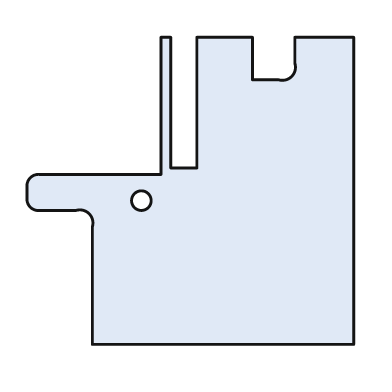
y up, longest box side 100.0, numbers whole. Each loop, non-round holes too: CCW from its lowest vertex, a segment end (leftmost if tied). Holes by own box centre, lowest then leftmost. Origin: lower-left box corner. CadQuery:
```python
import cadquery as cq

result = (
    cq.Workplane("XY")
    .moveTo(20.0, 0.0)
    .lineTo(100.0, 0.0)
    .lineTo(100.0, 94.0)
    .lineTo(82.0, 94.0)
    .lineTo(82.0, 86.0)
    .threePointArc((81.0, 82.0), (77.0, 81.0))
    .lineTo(69.0, 81.0)
    .lineTo(69.0, 94.0)
    .lineTo(52.0, 94.0)
    .lineTo(52.0, 54.0)
    .lineTo(44.0, 54.0)
    .lineTo(44.0, 94.0)
    .lineTo(41.0, 94.0)
    .lineTo(41.0, 52.0)
    .lineTo(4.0, 52.0)
    .threePointArc((1.0, 51.0), (0.0, 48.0))
    .lineTo(0.0, 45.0)
    .threePointArc((1.0, 42.0), (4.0, 41.0))
    .lineTo(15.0, 41.0)
    .threePointArc((19.0, 40.0), (20.0, 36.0))
    .close()
    .moveTo(35.0, 44.0)
    .circle(3.0)
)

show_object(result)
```